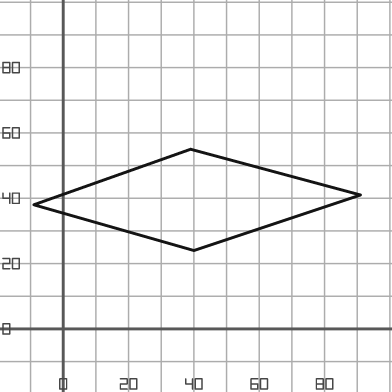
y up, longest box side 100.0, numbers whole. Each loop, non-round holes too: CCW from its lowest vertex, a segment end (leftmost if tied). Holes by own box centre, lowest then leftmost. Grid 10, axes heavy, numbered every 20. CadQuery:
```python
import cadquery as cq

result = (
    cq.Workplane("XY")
    .moveTo(40.0, 24.0)
    .lineTo(91.0, 41.0)
    .lineTo(39.0, 55.0)
    .lineTo(-9.0, 38.0)
    .close()
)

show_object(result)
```